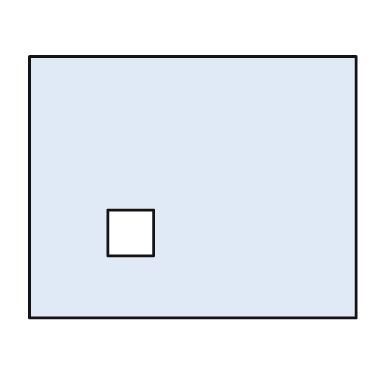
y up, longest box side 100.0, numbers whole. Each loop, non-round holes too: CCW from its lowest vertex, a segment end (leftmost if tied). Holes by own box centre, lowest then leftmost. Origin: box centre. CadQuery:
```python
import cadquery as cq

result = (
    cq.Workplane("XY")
    .moveTo(-50.0, -40.0)
    .lineTo(50.0, -40.0)
    .lineTo(50.0, 40.0)
    .lineTo(-50.0, 40.0)
    .close()
    .moveTo(-26.0, -21.0)
    .lineTo(-12.0, -21.0)
    .lineTo(-12.0, -7.0)
    .lineTo(-26.0, -7.0)
    .close()
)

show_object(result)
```